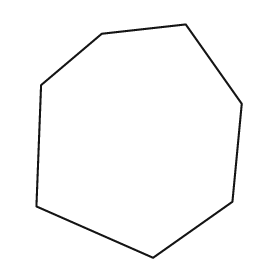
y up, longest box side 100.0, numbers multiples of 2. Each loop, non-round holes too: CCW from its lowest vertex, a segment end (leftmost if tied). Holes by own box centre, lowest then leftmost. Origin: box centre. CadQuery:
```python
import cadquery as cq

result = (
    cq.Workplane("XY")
    .moveTo(6.0, -50.0)
    .lineTo(40.0, -26.0)
    .lineTo(44.0, 16.0)
    .lineTo(20.0, 50.0)
    .lineTo(-16.0, 46.0)
    .lineTo(-42.0, 24.0)
    .lineTo(-44.0, -28.0)
    .close()
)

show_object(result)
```